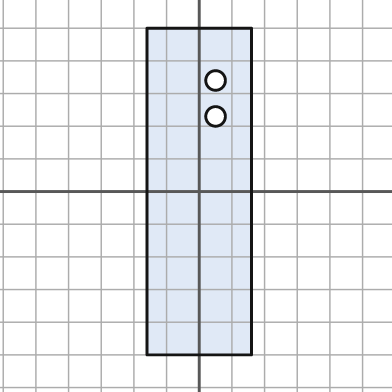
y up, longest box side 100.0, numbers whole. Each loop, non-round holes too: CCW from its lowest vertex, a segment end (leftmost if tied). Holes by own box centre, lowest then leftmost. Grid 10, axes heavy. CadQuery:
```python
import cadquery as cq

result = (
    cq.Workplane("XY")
    .moveTo(-16.0, -50.0)
    .lineTo(16.0, -50.0)
    .lineTo(16.0, 50.0)
    .lineTo(-16.0, 50.0)
    .close()
    .moveTo(5.0, 23.0)
    .circle(3.0)
    .moveTo(5.0, 34.0)
    .circle(3.0)
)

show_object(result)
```